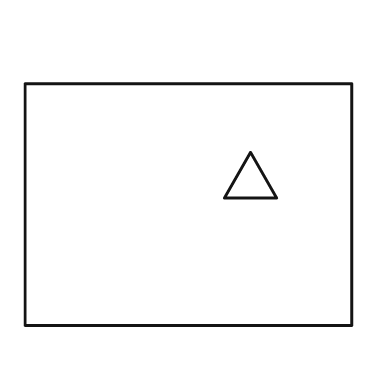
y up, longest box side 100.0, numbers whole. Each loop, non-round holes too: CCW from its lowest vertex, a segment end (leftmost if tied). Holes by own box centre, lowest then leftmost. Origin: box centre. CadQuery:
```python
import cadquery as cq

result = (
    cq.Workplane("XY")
    .moveTo(-50.0, -37.0)
    .lineTo(50.0, -37.0)
    .lineTo(50.0, 37.0)
    .lineTo(-50.0, 37.0)
    .close()
    .moveTo(11.0, 2.0)
    .lineTo(27.0, 2.0)
    .lineTo(19.0, 16.0)
    .close()
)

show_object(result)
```